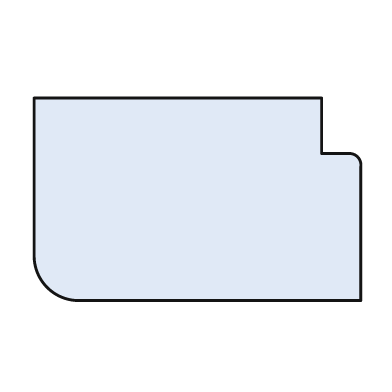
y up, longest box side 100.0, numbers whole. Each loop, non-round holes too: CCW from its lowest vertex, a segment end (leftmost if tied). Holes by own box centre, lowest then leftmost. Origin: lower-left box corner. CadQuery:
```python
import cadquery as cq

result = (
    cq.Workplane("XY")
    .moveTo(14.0, 0.0)
    .lineTo(100.0, 0.0)
    .lineTo(100.0, 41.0)
    .threePointArc((99.0, 44.0), (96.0, 45.0))
    .lineTo(88.0, 45.0)
    .lineTo(88.0, 62.0)
    .lineTo(0.0, 62.0)
    .lineTo(0.0, 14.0)
    .threePointArc((4.0, 4.0), (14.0, 0.0))
    .close()
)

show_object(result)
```